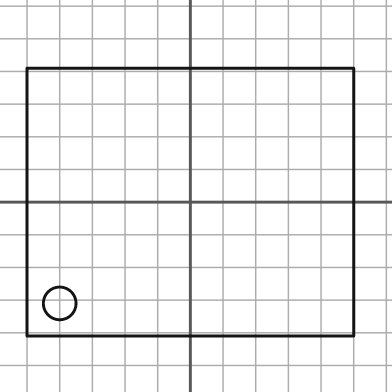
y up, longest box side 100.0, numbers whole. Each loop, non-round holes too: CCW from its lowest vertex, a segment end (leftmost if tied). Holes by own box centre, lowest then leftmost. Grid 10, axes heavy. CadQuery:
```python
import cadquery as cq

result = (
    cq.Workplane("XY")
    .moveTo(-50.0, -41.0)
    .lineTo(50.0, -41.0)
    .lineTo(50.0, 41.0)
    .lineTo(-50.0, 41.0)
    .close()
    .moveTo(-40.0, -31.0)
    .circle(5.0)
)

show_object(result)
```